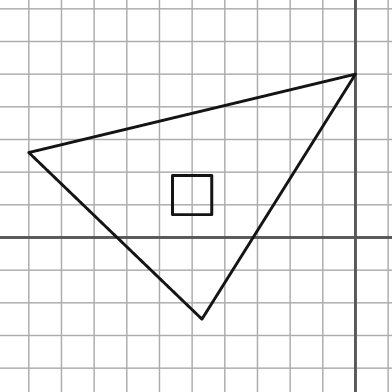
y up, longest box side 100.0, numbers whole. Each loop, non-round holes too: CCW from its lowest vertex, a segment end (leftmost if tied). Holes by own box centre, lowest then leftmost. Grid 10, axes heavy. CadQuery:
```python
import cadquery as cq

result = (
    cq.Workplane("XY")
    .moveTo(-47.0, -25.0)
    .lineTo(0.0, 50.0)
    .lineTo(-100.0, 26.0)
    .close()
    .moveTo(-56.0, 7.0)
    .lineTo(-44.0, 7.0)
    .lineTo(-44.0, 19.0)
    .lineTo(-56.0, 19.0)
    .close()
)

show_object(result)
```